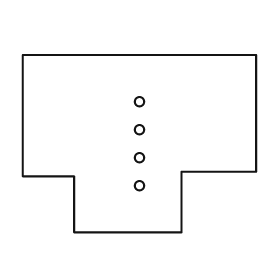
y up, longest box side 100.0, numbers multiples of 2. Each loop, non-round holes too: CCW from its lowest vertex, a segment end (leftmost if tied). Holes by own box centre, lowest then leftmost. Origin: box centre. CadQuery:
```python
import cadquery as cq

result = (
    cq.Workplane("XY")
    .moveTo(-28.0, -38.0)
    .lineTo(18.0, -38.0)
    .lineTo(18.0, -12.0)
    .lineTo(50.0, -12.0)
    .lineTo(50.0, 38.0)
    .lineTo(-50.0, 38.0)
    .lineTo(-50.0, -14.0)
    .lineTo(-28.0, -14.0)
    .close()
    .moveTo(0.0, -18.0)
    .circle(2.0)
    .moveTo(0.0, -6.0)
    .circle(2.0)
    .moveTo(0.0, 6.0)
    .circle(2.0)
    .moveTo(0.0, 18.0)
    .circle(2.0)
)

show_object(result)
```